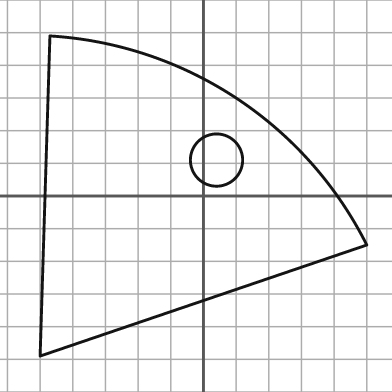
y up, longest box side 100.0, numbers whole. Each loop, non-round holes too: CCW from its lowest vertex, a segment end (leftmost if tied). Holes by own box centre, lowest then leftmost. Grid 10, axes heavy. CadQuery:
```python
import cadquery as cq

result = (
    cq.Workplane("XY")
    .moveTo(-50.0, -49.0)
    .lineTo(50.0, -15.0)
    .threePointArc((10.0, 30.0), (-47.0, 49.0))
    .close()
    .moveTo(4.0, 11.0)
    .circle(8.0)
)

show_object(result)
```